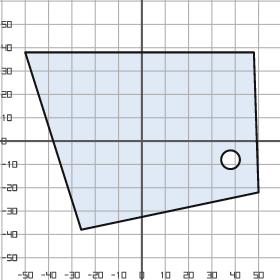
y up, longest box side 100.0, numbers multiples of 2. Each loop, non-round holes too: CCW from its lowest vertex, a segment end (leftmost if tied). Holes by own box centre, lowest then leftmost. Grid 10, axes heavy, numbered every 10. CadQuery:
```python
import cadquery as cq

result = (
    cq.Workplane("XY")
    .moveTo(-26.0, -38.0)
    .lineTo(50.0, -22.0)
    .lineTo(48.0, 38.0)
    .lineTo(-50.0, 38.0)
    .close()
    .moveTo(38.0, -8.0)
    .circle(4.0)
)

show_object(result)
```